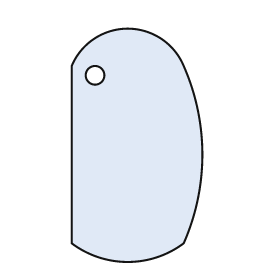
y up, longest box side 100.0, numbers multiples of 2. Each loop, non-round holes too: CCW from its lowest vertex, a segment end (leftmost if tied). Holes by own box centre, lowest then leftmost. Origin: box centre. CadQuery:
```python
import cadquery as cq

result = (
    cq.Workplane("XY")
    .moveTo(-28.0, -42.0)
    .threePointArc((-4.0, -50.0), (20.0, -42.0))
    .threePointArc((28.0, -4.0), (20.0, 34.0))
    .threePointArc((-4.0, 50.0), (-28.0, 34.0))
    .close()
    .moveTo(-18.0, 30.0)
    .circle(4.0)
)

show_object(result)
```